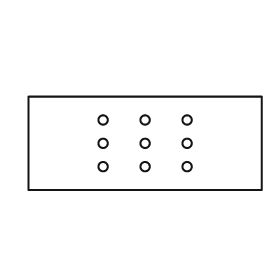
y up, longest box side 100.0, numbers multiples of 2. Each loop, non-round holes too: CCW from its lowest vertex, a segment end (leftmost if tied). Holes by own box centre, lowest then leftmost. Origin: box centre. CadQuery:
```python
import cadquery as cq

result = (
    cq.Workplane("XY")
    .moveTo(-50.0, -20.0)
    .lineTo(50.0, -20.0)
    .lineTo(50.0, 20.0)
    .lineTo(-50.0, 20.0)
    .close()
    .moveTo(-18.0, -10.0)
    .circle(2.0)
    .moveTo(0.0, -10.0)
    .circle(2.0)
    .moveTo(18.0, -10.0)
    .circle(2.0)
    .moveTo(-18.0, 0.0)
    .circle(2.0)
    .moveTo(0.0, 0.0)
    .circle(2.0)
    .moveTo(18.0, 0.0)
    .circle(2.0)
    .moveTo(-18.0, 10.0)
    .circle(2.0)
    .moveTo(0.0, 10.0)
    .circle(2.0)
    .moveTo(18.0, 10.0)
    .circle(2.0)
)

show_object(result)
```